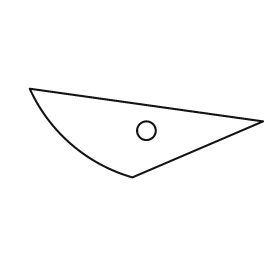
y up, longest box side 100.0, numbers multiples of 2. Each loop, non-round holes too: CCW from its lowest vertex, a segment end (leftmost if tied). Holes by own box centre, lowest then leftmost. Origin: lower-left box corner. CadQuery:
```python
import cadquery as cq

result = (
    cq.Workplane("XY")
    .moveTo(44.0, 0.0)
    .lineTo(100.0, 24.0)
    .lineTo(0.0, 38.0)
    .threePointArc((18.0, 14.0), (44.0, 0.0))
    .close()
    .moveTo(50.0, 20.0)
    .circle(4.0)
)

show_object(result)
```